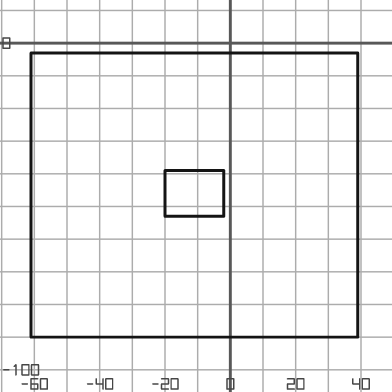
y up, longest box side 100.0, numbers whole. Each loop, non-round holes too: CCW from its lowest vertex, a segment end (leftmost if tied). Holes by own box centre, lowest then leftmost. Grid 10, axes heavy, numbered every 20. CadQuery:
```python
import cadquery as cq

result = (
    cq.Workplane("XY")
    .moveTo(-61.0, -90.0)
    .lineTo(39.0, -90.0)
    .lineTo(39.0, -3.0)
    .lineTo(-61.0, -3.0)
    .close()
    .moveTo(-20.0, -53.0)
    .lineTo(-2.0, -53.0)
    .lineTo(-2.0, -39.0)
    .lineTo(-20.0, -39.0)
    .close()
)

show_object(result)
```